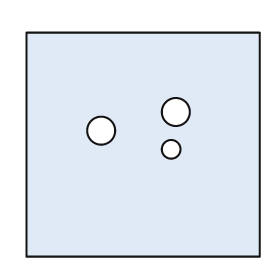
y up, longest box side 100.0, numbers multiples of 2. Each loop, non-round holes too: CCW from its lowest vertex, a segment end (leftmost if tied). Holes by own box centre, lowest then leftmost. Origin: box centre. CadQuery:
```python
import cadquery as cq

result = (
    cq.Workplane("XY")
    .moveTo(-50.0, -48.0)
    .lineTo(50.0, -48.0)
    .lineTo(50.0, 48.0)
    .lineTo(-50.0, 48.0)
    .close()
    .moveTo(12.0, -2.0)
    .circle(4.0)
    .moveTo(-18.0, 6.0)
    .circle(6.0)
    .moveTo(14.0, 14.0)
    .circle(6.0)
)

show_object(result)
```